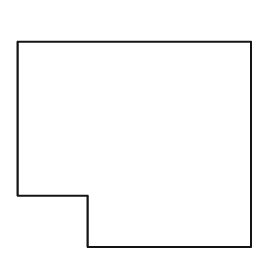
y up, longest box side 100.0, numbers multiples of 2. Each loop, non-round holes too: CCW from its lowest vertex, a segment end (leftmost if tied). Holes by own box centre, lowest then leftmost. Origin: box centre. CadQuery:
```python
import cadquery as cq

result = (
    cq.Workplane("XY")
    .moveTo(-20.0, -44.0)
    .lineTo(50.0, -44.0)
    .lineTo(50.0, 44.0)
    .lineTo(-50.0, 44.0)
    .lineTo(-50.0, -22.0)
    .lineTo(-20.0, -22.0)
    .close()
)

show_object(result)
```